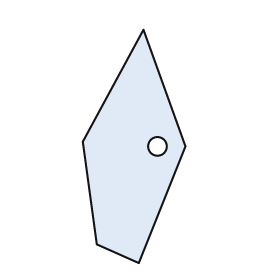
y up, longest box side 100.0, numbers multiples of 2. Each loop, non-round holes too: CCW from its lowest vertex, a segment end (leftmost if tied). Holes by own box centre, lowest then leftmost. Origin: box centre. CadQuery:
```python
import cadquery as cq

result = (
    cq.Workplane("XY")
    .moveTo(2.0, -50.0)
    .lineTo(22.0, 0.0)
    .lineTo(4.0, 50.0)
    .lineTo(-22.0, 2.0)
    .lineTo(-16.0, -42.0)
    .close()
    .moveTo(10.0, 0.0)
    .circle(4.0)
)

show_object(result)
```